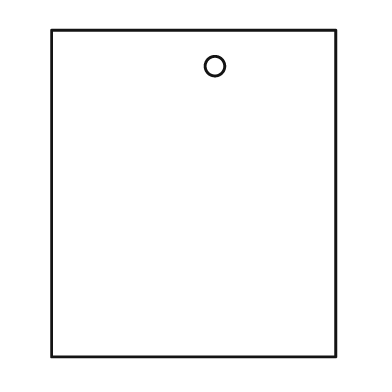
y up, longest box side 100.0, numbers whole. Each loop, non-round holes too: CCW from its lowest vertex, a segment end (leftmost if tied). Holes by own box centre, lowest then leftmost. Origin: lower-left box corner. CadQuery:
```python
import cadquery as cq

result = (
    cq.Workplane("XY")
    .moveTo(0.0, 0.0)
    .lineTo(87.0, 0.0)
    .lineTo(87.0, 100.0)
    .lineTo(0.0, 100.0)
    .close()
    .moveTo(50.0, 89.0)
    .circle(3.0)
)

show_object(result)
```